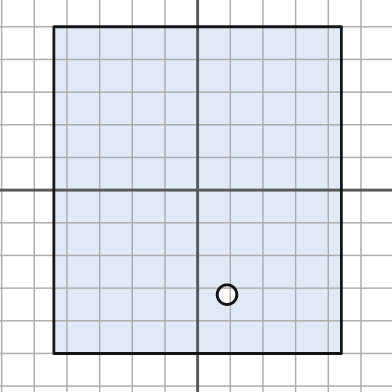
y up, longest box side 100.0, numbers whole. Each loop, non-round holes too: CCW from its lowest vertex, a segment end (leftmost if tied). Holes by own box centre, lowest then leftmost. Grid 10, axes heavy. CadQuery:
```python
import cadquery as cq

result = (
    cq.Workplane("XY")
    .moveTo(-44.0, -50.0)
    .lineTo(44.0, -50.0)
    .lineTo(44.0, 50.0)
    .lineTo(-44.0, 50.0)
    .close()
    .moveTo(9.0, -32.0)
    .circle(3.0)
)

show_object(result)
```